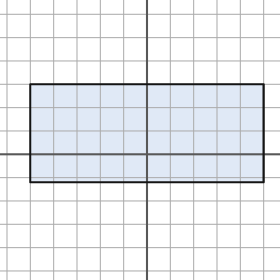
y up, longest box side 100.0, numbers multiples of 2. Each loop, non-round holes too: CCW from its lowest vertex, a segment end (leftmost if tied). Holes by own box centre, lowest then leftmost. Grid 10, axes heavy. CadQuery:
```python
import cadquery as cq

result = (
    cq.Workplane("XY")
    .moveTo(-50.0, -12.0)
    .lineTo(50.0, -12.0)
    .lineTo(50.0, 30.0)
    .lineTo(-50.0, 30.0)
    .close()
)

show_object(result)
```